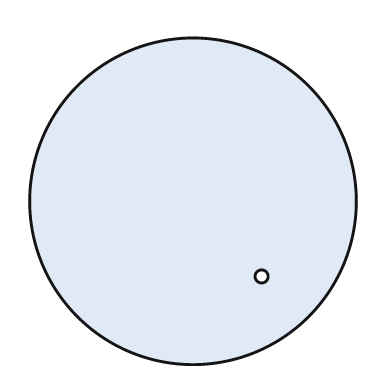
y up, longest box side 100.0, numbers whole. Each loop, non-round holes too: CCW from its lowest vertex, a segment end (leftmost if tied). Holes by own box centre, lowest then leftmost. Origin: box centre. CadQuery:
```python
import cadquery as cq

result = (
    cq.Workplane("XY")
    .moveTo(0.0, 0.0)
    .circle(50.0)
    .moveTo(21.0, -23.0)
    .circle(2.0)
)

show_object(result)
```